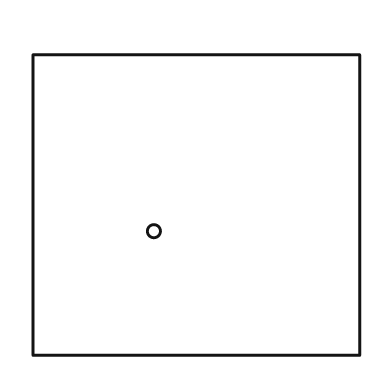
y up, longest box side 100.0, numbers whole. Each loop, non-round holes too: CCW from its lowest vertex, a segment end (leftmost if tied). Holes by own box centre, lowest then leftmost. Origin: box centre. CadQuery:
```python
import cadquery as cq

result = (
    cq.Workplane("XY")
    .moveTo(-50.0, -46.0)
    .lineTo(50.0, -46.0)
    .lineTo(50.0, 46.0)
    .lineTo(-50.0, 46.0)
    .close()
    .moveTo(-13.0, -8.0)
    .circle(2.0)
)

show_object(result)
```